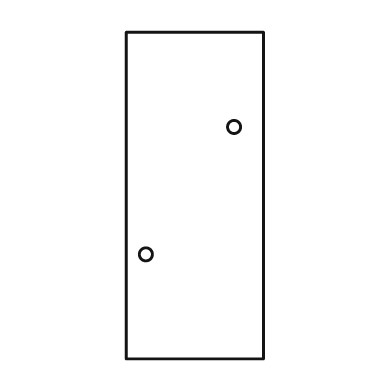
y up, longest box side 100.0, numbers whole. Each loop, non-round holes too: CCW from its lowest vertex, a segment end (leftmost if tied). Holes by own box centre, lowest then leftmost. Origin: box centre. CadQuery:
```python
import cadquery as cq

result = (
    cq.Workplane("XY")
    .moveTo(-21.0, -50.0)
    .lineTo(21.0, -50.0)
    .lineTo(21.0, 50.0)
    .lineTo(-21.0, 50.0)
    .close()
    .moveTo(-15.0, -18.0)
    .circle(2.0)
    .moveTo(12.0, 21.0)
    .circle(2.0)
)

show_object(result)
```